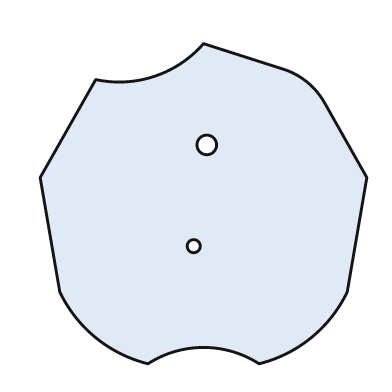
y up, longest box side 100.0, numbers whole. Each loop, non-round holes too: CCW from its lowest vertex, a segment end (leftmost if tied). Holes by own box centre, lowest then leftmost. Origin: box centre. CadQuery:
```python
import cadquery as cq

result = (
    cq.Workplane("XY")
    .moveTo(-17.0, -49.0)
    .threePointArc((0.0, -44.0), (17.0, -49.0))
    .threePointArc((33.0, -41.0), (44.0, -27.0))
    .lineTo(50.0, 8.0)
    .lineTo(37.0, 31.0)
    .threePointArc((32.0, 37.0), (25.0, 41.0))
    .lineTo(0.0, 49.0)
    .threePointArc((-15.0, 39.0), (-33.0, 38.0))
    .lineTo(-50.0, 8.0)
    .lineTo(-44.0, -27.0)
    .threePointArc((-33.0, -41.0), (-17.0, -49.0))
    .close()
    .moveTo(-3.0, -13.0)
    .circle(2.0)
    .moveTo(1.0, 18.0)
    .circle(3.0)
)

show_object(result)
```